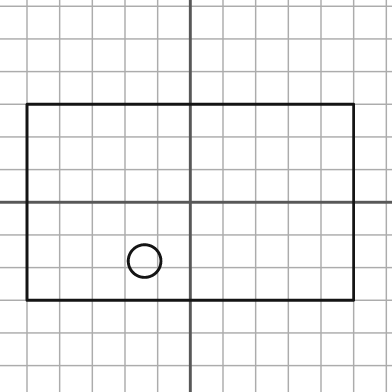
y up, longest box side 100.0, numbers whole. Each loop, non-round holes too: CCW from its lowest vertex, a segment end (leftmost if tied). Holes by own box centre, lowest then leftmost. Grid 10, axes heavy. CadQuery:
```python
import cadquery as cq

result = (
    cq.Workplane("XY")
    .moveTo(-50.0, -30.0)
    .lineTo(50.0, -30.0)
    .lineTo(50.0, 30.0)
    .lineTo(-50.0, 30.0)
    .close()
    .moveTo(-14.0, -18.0)
    .circle(5.0)
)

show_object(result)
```